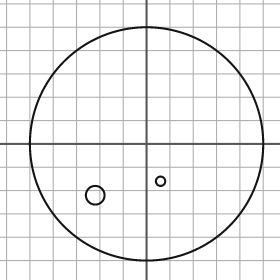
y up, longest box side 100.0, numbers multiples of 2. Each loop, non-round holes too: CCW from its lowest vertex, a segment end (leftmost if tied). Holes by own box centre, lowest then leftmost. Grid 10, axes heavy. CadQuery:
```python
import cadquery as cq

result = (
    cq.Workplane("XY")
    .moveTo(0.0, 0.0)
    .circle(50.0)
    .moveTo(-22.0, -22.0)
    .circle(4.0)
    .moveTo(6.0, -16.0)
    .circle(2.0)
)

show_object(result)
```